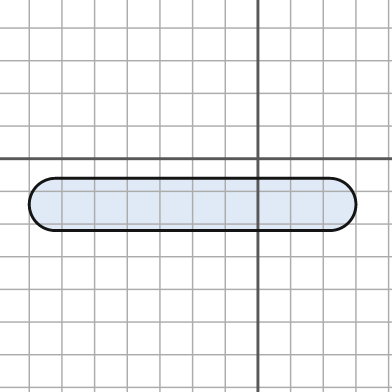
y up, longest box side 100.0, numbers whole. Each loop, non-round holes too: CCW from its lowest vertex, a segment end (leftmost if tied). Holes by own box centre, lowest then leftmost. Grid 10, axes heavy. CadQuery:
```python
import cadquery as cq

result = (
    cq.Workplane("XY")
    .moveTo(-62.0, -22.0)
    .lineTo(22.0, -22.0)
    .threePointArc((30.0, -14.0), (22.0, -6.0))
    .lineTo(-62.0, -6.0)
    .threePointArc((-70.0, -14.0), (-62.0, -22.0))
    .close()
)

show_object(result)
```